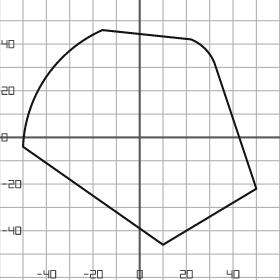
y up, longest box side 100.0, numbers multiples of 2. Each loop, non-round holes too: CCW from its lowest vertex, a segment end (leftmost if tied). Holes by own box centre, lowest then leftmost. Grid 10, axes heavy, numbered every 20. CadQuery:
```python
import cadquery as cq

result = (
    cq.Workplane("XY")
    .moveTo(10.0, -46.0)
    .lineTo(50.0, -22.0)
    .lineTo(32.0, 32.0)
    .threePointArc((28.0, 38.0), (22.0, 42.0))
    .lineTo(-16.0, 46.0)
    .threePointArc((-40.0, 26.0), (-50.0, -4.0))
    .close()
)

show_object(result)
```